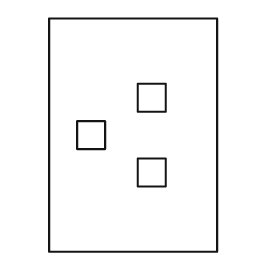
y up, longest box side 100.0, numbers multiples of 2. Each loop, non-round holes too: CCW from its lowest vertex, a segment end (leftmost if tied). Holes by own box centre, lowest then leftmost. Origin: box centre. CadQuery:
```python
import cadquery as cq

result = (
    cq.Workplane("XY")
    .moveTo(-36.0, -50.0)
    .lineTo(36.0, -50.0)
    .lineTo(36.0, 50.0)
    .lineTo(-36.0, 50.0)
    .close()
    .moveTo(2.0, -22.0)
    .lineTo(14.0, -22.0)
    .lineTo(14.0, -10.0)
    .lineTo(2.0, -10.0)
    .close()
    .moveTo(-24.0, -6.0)
    .lineTo(-12.0, -6.0)
    .lineTo(-12.0, 6.0)
    .lineTo(-24.0, 6.0)
    .close()
    .moveTo(2.0, 10.0)
    .lineTo(14.0, 10.0)
    .lineTo(14.0, 22.0)
    .lineTo(2.0, 22.0)
    .close()
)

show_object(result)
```